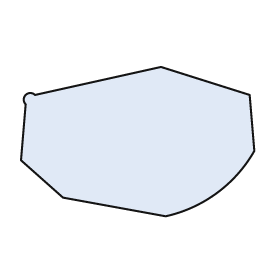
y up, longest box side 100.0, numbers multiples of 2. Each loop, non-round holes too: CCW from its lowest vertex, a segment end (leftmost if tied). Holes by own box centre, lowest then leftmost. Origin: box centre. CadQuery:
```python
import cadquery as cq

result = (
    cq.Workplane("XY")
    .moveTo(12.0, -32.0)
    .threePointArc((34.0, -22.0), (50.0, -4.0))
    .lineTo(48.0, 20.0)
    .lineTo(10.0, 32.0)
    .lineTo(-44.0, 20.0)
    .threePointArc((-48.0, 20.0), (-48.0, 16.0))
    .lineTo(-50.0, -8.0)
    .lineTo(-32.0, -24.0)
    .close()
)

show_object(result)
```